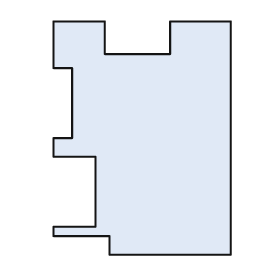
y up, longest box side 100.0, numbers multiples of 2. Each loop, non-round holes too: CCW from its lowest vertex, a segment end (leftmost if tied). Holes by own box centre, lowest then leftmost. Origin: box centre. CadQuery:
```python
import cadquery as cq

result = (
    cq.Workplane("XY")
    .moveTo(-14.0, -50.0)
    .lineTo(38.0, -50.0)
    .lineTo(38.0, 50.0)
    .lineTo(12.0, 50.0)
    .lineTo(12.0, 36.0)
    .lineTo(-16.0, 36.0)
    .lineTo(-16.0, 50.0)
    .lineTo(-38.0, 50.0)
    .lineTo(-38.0, 30.0)
    .lineTo(-30.0, 30.0)
    .lineTo(-30.0, 0.0)
    .lineTo(-38.0, 0.0)
    .lineTo(-38.0, -8.0)
    .lineTo(-20.0, -8.0)
    .lineTo(-20.0, -38.0)
    .lineTo(-38.0, -38.0)
    .lineTo(-38.0, -42.0)
    .lineTo(-14.0, -42.0)
    .close()
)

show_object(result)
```